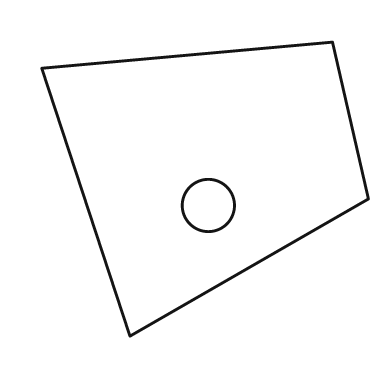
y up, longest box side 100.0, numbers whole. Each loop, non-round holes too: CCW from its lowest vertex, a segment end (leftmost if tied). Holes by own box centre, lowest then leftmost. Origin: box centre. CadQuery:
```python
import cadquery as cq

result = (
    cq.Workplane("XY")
    .moveTo(-23.0, -45.0)
    .lineTo(50.0, -3.0)
    .lineTo(39.0, 45.0)
    .lineTo(-50.0, 37.0)
    .close()
    .moveTo(1.0, -5.0)
    .circle(8.0)
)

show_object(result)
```